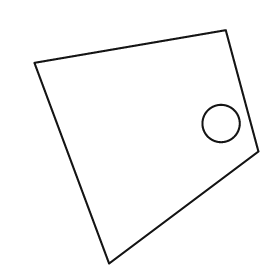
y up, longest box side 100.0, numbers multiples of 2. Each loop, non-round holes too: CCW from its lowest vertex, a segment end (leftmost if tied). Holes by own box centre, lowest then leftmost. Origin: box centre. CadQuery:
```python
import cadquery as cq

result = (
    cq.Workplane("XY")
    .moveTo(-16.0, -50.0)
    .lineTo(48.0, -2.0)
    .lineTo(34.0, 50.0)
    .lineTo(-48.0, 36.0)
    .close()
    .moveTo(32.0, 10.0)
    .circle(8.0)
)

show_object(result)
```